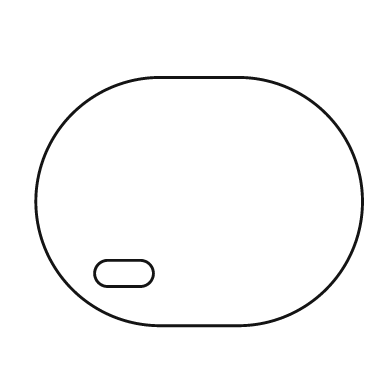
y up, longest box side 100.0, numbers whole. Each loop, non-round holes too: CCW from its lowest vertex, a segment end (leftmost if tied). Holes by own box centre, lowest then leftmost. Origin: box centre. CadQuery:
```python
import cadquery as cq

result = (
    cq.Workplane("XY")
    .moveTo(-12.0, -38.0)
    .lineTo(12.0, -38.0)
    .threePointArc((50.0, 0.0), (12.0, 38.0))
    .lineTo(-12.0, 38.0)
    .threePointArc((-50.0, 0.0), (-12.0, -38.0))
    .close()
    .moveTo(-28.0, -26.0)
    .lineTo(-18.0, -26.0)
    .threePointArc((-14.0, -22.0), (-18.0, -18.0))
    .lineTo(-28.0, -18.0)
    .threePointArc((-32.0, -22.0), (-28.0, -26.0))
    .close()
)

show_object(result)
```